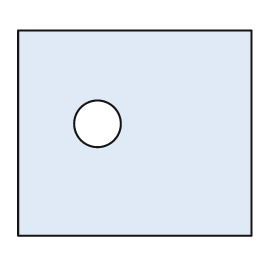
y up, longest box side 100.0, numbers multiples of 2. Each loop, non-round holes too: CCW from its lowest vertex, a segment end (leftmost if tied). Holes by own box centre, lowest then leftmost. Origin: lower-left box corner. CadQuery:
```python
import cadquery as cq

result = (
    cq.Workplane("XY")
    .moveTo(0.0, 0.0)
    .lineTo(100.0, 0.0)
    .lineTo(100.0, 88.0)
    .lineTo(0.0, 88.0)
    .close()
    .moveTo(34.0, 48.0)
    .circle(10.0)
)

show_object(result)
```